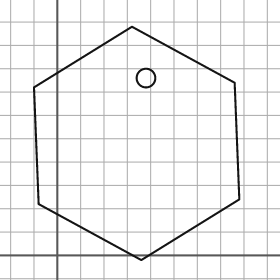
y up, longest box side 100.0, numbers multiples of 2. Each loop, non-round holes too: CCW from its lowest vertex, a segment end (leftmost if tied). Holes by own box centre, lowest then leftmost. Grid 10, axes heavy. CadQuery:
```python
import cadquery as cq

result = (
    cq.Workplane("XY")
    .moveTo(36.0, -2.0)
    .lineTo(78.0, 24.0)
    .lineTo(76.0, 74.0)
    .lineTo(32.0, 98.0)
    .lineTo(-10.0, 72.0)
    .lineTo(-8.0, 22.0)
    .close()
    .moveTo(38.0, 76.0)
    .circle(4.0)
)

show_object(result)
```